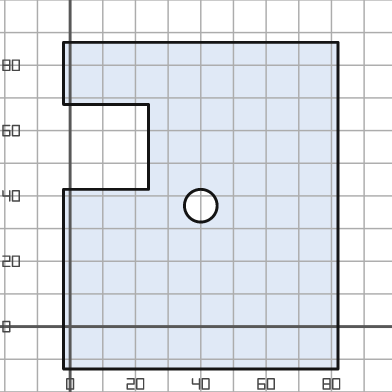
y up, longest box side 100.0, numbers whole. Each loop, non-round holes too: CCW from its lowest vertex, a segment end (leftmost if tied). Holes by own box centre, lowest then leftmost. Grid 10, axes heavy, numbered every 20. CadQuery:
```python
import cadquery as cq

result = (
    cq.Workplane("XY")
    .moveTo(-2.0, -13.0)
    .lineTo(82.0, -13.0)
    .lineTo(82.0, 87.0)
    .lineTo(-2.0, 87.0)
    .lineTo(-2.0, 68.0)
    .lineTo(24.0, 68.0)
    .lineTo(24.0, 42.0)
    .lineTo(-2.0, 42.0)
    .close()
    .moveTo(40.0, 37.0)
    .circle(5.0)
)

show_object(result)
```